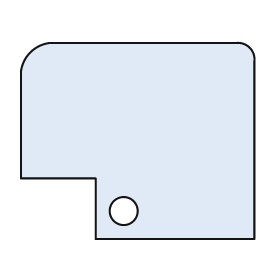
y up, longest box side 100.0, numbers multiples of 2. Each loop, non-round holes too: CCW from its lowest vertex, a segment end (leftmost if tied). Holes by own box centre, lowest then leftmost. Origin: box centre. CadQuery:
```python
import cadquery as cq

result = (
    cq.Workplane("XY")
    .moveTo(-18.0, -42.0)
    .lineTo(50.0, -42.0)
    .lineTo(50.0, 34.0)
    .threePointArc((48.0, 40.0), (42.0, 42.0))
    .lineTo(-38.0, 42.0)
    .threePointArc((-46.0, 38.0), (-50.0, 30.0))
    .lineTo(-50.0, -16.0)
    .lineTo(-18.0, -16.0)
    .close()
    .moveTo(-6.0, -30.0)
    .circle(6.0)
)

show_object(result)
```